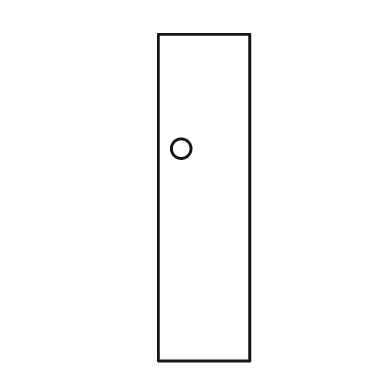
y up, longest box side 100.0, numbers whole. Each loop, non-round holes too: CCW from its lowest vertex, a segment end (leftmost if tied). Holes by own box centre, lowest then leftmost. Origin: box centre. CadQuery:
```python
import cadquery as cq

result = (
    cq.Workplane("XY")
    .moveTo(-14.0, -50.0)
    .lineTo(14.0, -50.0)
    .lineTo(14.0, 50.0)
    .lineTo(-14.0, 50.0)
    .close()
    .moveTo(-7.0, 15.0)
    .circle(3.0)
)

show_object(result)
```